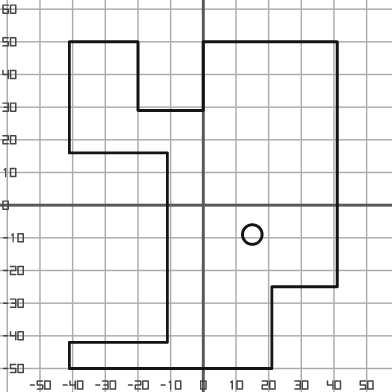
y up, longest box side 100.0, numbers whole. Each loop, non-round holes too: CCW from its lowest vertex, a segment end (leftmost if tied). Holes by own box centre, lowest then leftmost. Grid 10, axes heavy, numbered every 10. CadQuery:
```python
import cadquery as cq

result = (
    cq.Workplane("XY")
    .moveTo(-41.0, -50.0)
    .lineTo(21.0, -50.0)
    .lineTo(21.0, -25.0)
    .lineTo(41.0, -25.0)
    .lineTo(41.0, 50.0)
    .lineTo(0.0, 50.0)
    .lineTo(0.0, 29.0)
    .lineTo(-20.0, 29.0)
    .lineTo(-20.0, 50.0)
    .lineTo(-41.0, 50.0)
    .lineTo(-41.0, 16.0)
    .lineTo(-11.0, 16.0)
    .lineTo(-11.0, -42.0)
    .lineTo(-41.0, -42.0)
    .close()
    .moveTo(15.0, -9.0)
    .circle(3.0)
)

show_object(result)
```